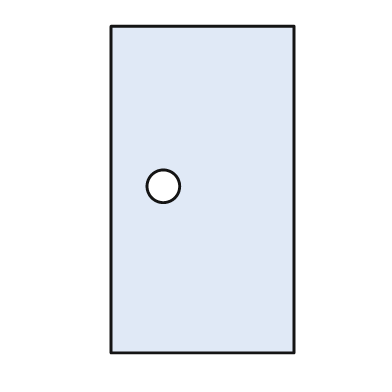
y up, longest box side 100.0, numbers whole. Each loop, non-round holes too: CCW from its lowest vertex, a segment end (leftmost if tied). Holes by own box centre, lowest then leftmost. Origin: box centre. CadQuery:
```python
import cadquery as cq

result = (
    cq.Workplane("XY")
    .moveTo(-28.0, -50.0)
    .lineTo(28.0, -50.0)
    .lineTo(28.0, 50.0)
    .lineTo(-28.0, 50.0)
    .close()
    .moveTo(-12.0, 1.0)
    .circle(5.0)
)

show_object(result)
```